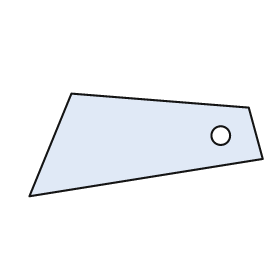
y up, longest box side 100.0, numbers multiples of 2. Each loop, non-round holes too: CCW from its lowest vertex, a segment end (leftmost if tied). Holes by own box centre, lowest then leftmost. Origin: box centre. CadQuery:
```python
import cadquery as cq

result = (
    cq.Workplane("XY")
    .moveTo(-50.0, -22.0)
    .lineTo(50.0, -6.0)
    .lineTo(44.0, 16.0)
    .lineTo(-32.0, 22.0)
    .close()
    .moveTo(32.0, 4.0)
    .circle(4.0)
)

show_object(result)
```